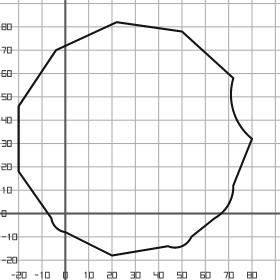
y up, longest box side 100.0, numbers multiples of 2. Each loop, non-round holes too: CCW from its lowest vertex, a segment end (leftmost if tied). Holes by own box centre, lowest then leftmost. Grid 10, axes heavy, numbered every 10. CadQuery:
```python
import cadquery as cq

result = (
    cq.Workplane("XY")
    .moveTo(20.0, -18.0)
    .lineTo(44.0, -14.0)
    .threePointArc((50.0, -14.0), (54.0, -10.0))
    .lineTo(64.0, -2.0)
    .threePointArc((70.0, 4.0), (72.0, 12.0))
    .lineTo(80.0, 32.0)
    .threePointArc((72.0, 44.0), (72.0, 58.0))
    .lineTo(50.0, 78.0)
    .lineTo(22.0, 82.0)
    .lineTo(-4.0, 70.0)
    .lineTo(-20.0, 46.0)
    .lineTo(-20.0, 18.0)
    .lineTo(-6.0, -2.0)
    .threePointArc((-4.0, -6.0), (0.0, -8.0))
    .close()
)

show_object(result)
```